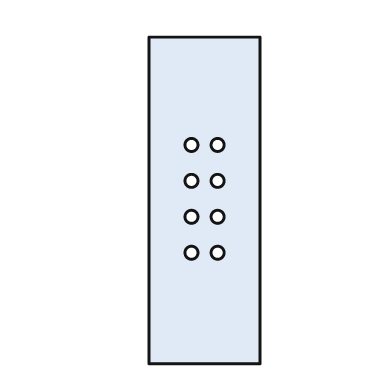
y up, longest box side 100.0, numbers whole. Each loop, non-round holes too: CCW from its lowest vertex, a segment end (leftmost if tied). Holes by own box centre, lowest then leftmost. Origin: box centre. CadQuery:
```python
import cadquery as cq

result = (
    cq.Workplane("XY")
    .moveTo(-17.0, -50.0)
    .lineTo(17.0, -50.0)
    .lineTo(17.0, 50.0)
    .lineTo(-17.0, 50.0)
    .close()
    .moveTo(-4.0, -16.0)
    .circle(2.0)
    .moveTo(4.0, -16.0)
    .circle(2.0)
    .moveTo(-4.0, -5.0)
    .circle(2.0)
    .moveTo(4.0, -5.0)
    .circle(2.0)
    .moveTo(-4.0, 6.0)
    .circle(2.0)
    .moveTo(4.0, 6.0)
    .circle(2.0)
    .moveTo(-4.0, 17.0)
    .circle(2.0)
    .moveTo(4.0, 17.0)
    .circle(2.0)
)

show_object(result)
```